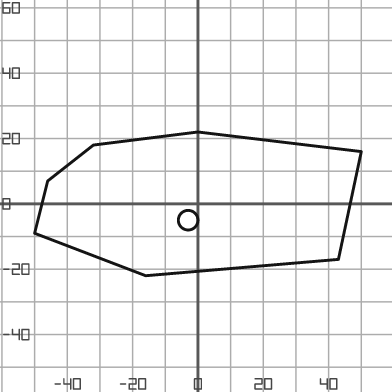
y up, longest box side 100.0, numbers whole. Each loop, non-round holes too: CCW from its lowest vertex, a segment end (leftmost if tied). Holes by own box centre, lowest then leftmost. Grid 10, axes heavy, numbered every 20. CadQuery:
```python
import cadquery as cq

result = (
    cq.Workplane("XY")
    .moveTo(-16.0, -22.0)
    .lineTo(43.0, -17.0)
    .lineTo(50.0, 16.0)
    .lineTo(0.0, 22.0)
    .lineTo(-32.0, 18.0)
    .lineTo(-46.0, 7.0)
    .lineTo(-50.0, -9.0)
    .close()
    .moveTo(-3.0, -5.0)
    .circle(3.0)
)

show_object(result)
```